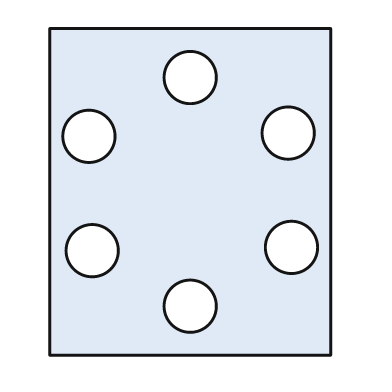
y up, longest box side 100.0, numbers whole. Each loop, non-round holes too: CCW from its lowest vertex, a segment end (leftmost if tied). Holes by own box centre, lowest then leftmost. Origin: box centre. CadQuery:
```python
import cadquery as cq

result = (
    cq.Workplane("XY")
    .moveTo(-43.0, -50.0)
    .lineTo(43.0, -50.0)
    .lineTo(43.0, 50.0)
    .lineTo(-43.0, 50.0)
    .close()
    .moveTo(0.0, -35.0)
    .circle(8.0)
    .moveTo(-30.0, -18.0)
    .circle(8.0)
    .moveTo(31.0, -17.0)
    .circle(8.0)
    .moveTo(-31.0, 17.0)
    .circle(8.0)
    .moveTo(30.0, 18.0)
    .circle(8.0)
    .moveTo(0.0, 35.0)
    .circle(8.0)
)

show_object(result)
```